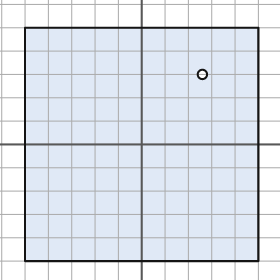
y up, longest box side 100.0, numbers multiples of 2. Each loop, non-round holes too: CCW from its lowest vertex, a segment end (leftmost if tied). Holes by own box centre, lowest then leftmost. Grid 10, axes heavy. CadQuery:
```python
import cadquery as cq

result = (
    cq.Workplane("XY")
    .moveTo(-50.0, -50.0)
    .lineTo(50.0, -50.0)
    .lineTo(50.0, 50.0)
    .lineTo(-50.0, 50.0)
    .close()
    .moveTo(26.0, 30.0)
    .circle(2.0)
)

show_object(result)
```